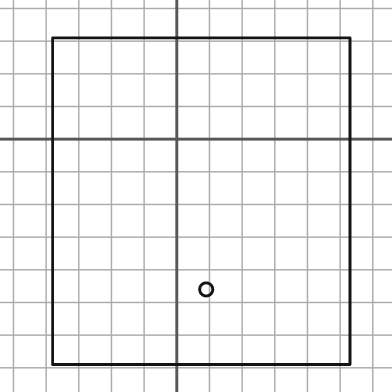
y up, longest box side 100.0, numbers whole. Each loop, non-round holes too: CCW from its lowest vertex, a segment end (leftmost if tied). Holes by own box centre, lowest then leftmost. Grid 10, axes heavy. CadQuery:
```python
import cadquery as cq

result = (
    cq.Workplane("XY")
    .moveTo(-38.0, -69.0)
    .lineTo(53.0, -69.0)
    .lineTo(53.0, 31.0)
    .lineTo(-38.0, 31.0)
    .close()
    .moveTo(9.0, -46.0)
    .circle(2.0)
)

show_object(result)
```